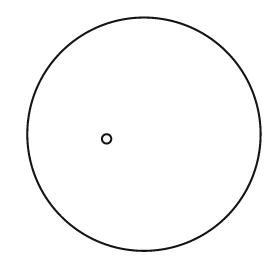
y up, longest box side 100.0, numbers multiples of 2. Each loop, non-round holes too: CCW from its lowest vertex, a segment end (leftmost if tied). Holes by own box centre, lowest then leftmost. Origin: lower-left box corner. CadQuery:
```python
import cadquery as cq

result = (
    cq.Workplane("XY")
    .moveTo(50.0, 50.0)
    .circle(50.0)
    .moveTo(34.0, 48.0)
    .circle(2.0)
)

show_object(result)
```